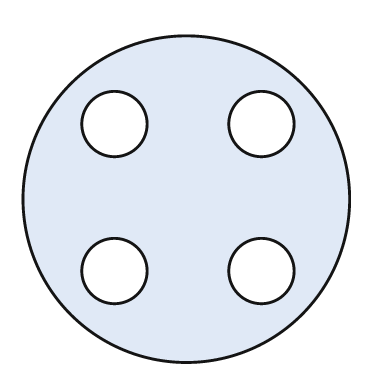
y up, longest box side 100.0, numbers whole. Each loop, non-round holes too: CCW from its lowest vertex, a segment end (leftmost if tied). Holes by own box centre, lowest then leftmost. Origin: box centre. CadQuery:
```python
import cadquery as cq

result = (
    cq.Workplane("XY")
    .moveTo(0.0, 0.0)
    .circle(50.0)
    .moveTo(-22.0, -22.0)
    .circle(10.0)
    .moveTo(23.0, -22.0)
    .circle(10.0)
    .moveTo(-22.0, 23.0)
    .circle(10.0)
    .moveTo(23.0, 23.0)
    .circle(10.0)
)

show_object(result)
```